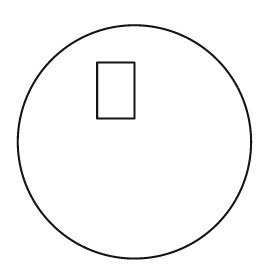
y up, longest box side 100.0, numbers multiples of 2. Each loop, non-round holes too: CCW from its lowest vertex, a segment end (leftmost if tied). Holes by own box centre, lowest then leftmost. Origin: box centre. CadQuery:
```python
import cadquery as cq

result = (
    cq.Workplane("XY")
    .moveTo(0.0, 0.0)
    .circle(50.0)
    .moveTo(-16.0, 10.0)
    .lineTo(0.0, 10.0)
    .lineTo(0.0, 34.0)
    .lineTo(-16.0, 34.0)
    .close()
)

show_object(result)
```